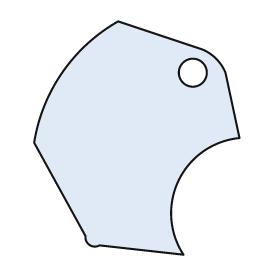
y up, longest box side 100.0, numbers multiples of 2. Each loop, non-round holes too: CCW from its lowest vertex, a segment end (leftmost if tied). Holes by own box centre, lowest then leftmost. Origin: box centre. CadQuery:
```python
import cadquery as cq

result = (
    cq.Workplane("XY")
    .moveTo(20.0, -50.0)
    .threePointArc((18.0, -18.0), (44.0, 0.0))
    .lineTo(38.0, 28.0)
    .threePointArc((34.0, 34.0), (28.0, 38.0))
    .lineTo(-8.0, 50.0)
    .threePointArc((-32.0, 28.0), (-44.0, -2.0))
    .lineTo(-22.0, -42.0)
    .threePointArc((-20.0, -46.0), (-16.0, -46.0))
    .close()
    .moveTo(24.0, 28.0)
    .circle(6.0)
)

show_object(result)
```